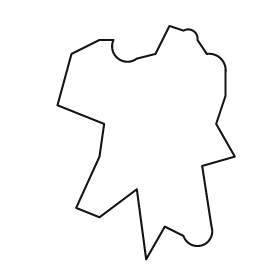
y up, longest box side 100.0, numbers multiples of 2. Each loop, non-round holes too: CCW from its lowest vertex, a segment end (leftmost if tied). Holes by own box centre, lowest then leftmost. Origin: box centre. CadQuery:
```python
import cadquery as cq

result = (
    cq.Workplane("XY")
    .moveTo(0.0, -50.0)
    .lineTo(8.0, -36.0)
    .lineTo(16.0, -40.0)
    .threePointArc((24.0, -44.0), (28.0, -36.0))
    .lineTo(24.0, -10.0)
    .lineTo(38.0, -6.0)
    .lineTo(30.0, 8.0)
    .lineTo(34.0, 20.0)
    .lineTo(34.0, 30.0)
    .threePointArc((32.0, 36.0), (26.0, 38.0))
    .lineTo(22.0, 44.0)
    .threePointArc((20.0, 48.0), (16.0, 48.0))
    .lineTo(10.0, 50.0)
    .lineTo(4.0, 38.0)
    .lineTo(-4.0, 36.0)
    .threePointArc((-12.0, 36.0), (-14.0, 44.0))
    .lineTo(-20.0, 44.0)
    .lineTo(-32.0, 38.0)
    .lineTo(-38.0, 16.0)
    .lineTo(-18.0, 8.0)
    .lineTo(-20.0, -6.0)
    .lineTo(-30.0, -28.0)
    .lineTo(-20.0, -32.0)
    .lineTo(-4.0, -20.0)
    .close()
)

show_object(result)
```